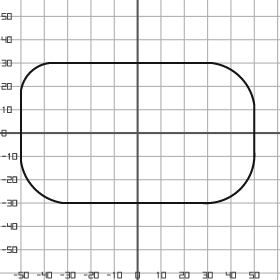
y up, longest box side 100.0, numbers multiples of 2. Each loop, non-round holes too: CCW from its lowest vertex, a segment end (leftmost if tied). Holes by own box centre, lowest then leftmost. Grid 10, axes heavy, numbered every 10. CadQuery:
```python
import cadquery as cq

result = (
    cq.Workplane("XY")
    .moveTo(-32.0, -30.0)
    .lineTo(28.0, -30.0)
    .threePointArc((44.0, -24.0), (50.0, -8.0))
    .lineTo(50.0, 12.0)
    .threePointArc((44.0, 24.0), (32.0, 30.0))
    .lineTo(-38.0, 30.0)
    .threePointArc((-46.0, 26.0), (-50.0, 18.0))
    .lineTo(-50.0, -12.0)
    .threePointArc((-44.0, -24.0), (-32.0, -30.0))
    .close()
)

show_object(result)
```